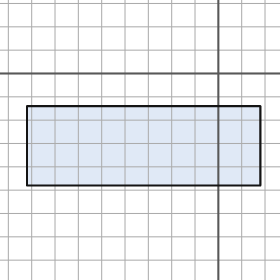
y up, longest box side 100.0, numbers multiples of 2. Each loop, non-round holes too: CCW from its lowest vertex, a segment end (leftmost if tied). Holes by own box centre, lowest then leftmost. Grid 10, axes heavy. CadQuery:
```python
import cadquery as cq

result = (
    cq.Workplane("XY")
    .moveTo(-82.0, -48.0)
    .lineTo(18.0, -48.0)
    .lineTo(18.0, -14.0)
    .lineTo(-82.0, -14.0)
    .close()
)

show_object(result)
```